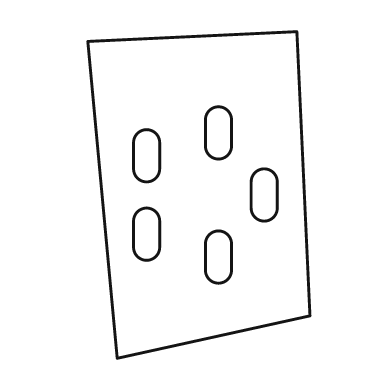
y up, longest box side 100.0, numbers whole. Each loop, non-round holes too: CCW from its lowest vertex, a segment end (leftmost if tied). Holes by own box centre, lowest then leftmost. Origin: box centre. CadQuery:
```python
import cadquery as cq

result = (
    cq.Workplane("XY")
    .moveTo(-25.0, -50.0)
    .lineTo(34.0, -37.0)
    .lineTo(30.0, 50.0)
    .lineTo(-34.0, 47.0)
    .close()
    .moveTo(2.0, -23.0)
    .threePointArc((6.0, -27.0), (10.0, -23.0))
    .lineTo(10.0, -15.0)
    .threePointArc((6.0, -11.0), (2.0, -15.0))
    .close()
    .moveTo(-20.0, -16.0)
    .threePointArc((-16.0, -20.0), (-12.0, -16.0))
    .lineTo(-12.0, -8.0)
    .threePointArc((-16.0, -4.0), (-20.0, -8.0))
    .close()
    .moveTo(16.0, -4.0)
    .threePointArc((20.0, -8.0), (24.0, -4.0))
    .lineTo(24.0, 4.0)
    .threePointArc((20.0, 8.0), (16.0, 4.0))
    .close()
    .moveTo(-20.0, 8.0)
    .threePointArc((-16.0, 4.0), (-12.0, 8.0))
    .lineTo(-12.0, 16.0)
    .threePointArc((-16.0, 20.0), (-20.0, 16.0))
    .close()
    .moveTo(2.0, 15.0)
    .threePointArc((6.0, 11.0), (10.0, 15.0))
    .lineTo(10.0, 23.0)
    .threePointArc((6.0, 27.0), (2.0, 23.0))
    .close()
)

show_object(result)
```